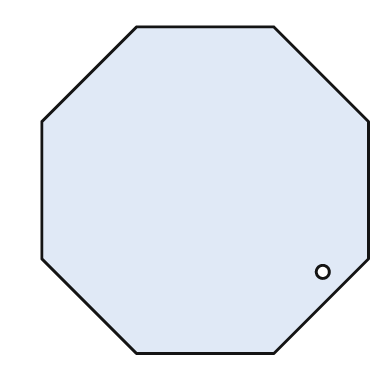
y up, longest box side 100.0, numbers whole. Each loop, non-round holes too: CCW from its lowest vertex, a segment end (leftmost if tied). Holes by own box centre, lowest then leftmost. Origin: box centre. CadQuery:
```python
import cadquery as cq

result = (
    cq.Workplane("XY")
    .moveTo(-21.0, -50.0)
    .lineTo(21.0, -50.0)
    .lineTo(50.0, -21.0)
    .lineTo(50.0, 21.0)
    .lineTo(21.0, 50.0)
    .lineTo(-21.0, 50.0)
    .lineTo(-50.0, 21.0)
    .lineTo(-50.0, -21.0)
    .close()
    .moveTo(36.0, -25.0)
    .circle(2.0)
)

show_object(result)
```